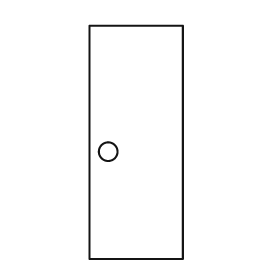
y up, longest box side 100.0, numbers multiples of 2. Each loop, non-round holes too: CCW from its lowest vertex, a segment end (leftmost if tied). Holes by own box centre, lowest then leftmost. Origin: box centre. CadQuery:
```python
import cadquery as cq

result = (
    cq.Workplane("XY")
    .moveTo(-20.0, -50.0)
    .lineTo(20.0, -50.0)
    .lineTo(20.0, 50.0)
    .lineTo(-20.0, 50.0)
    .close()
    .moveTo(-12.0, -4.0)
    .circle(4.0)
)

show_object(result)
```